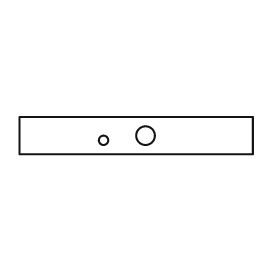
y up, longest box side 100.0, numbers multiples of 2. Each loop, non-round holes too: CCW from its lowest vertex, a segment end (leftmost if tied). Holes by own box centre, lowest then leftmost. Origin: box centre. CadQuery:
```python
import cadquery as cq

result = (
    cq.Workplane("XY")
    .moveTo(-50.0, -8.0)
    .lineTo(50.0, -8.0)
    .lineTo(50.0, 8.0)
    .lineTo(-50.0, 8.0)
    .close()
    .moveTo(-14.0, -2.0)
    .circle(2.0)
    .moveTo(4.0, 0.0)
    .circle(4.0)
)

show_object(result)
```